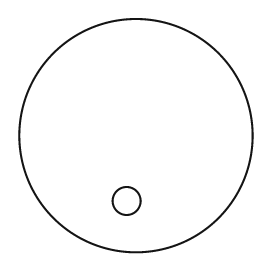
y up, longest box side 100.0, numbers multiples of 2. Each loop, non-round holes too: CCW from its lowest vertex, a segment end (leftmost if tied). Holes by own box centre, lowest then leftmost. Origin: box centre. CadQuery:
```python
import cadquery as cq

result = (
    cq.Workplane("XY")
    .moveTo(0.0, 0.0)
    .circle(50.0)
    .moveTo(-4.0, -28.0)
    .circle(6.0)
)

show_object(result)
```